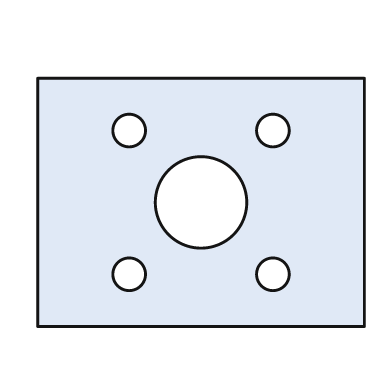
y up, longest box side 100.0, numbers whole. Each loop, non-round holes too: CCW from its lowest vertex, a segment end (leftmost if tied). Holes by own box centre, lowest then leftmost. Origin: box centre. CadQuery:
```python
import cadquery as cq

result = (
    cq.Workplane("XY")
    .moveTo(-50.0, -38.0)
    .lineTo(50.0, -38.0)
    .lineTo(50.0, 38.0)
    .lineTo(-50.0, 38.0)
    .close()
    .moveTo(-22.0, -22.0)
    .circle(5.0)
    .moveTo(22.0, -22.0)
    .circle(5.0)
    .moveTo(0.0, 0.0)
    .circle(14.0)
    .moveTo(-22.0, 22.0)
    .circle(5.0)
    .moveTo(22.0, 22.0)
    .circle(5.0)
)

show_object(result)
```